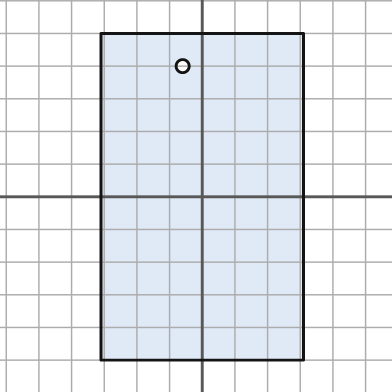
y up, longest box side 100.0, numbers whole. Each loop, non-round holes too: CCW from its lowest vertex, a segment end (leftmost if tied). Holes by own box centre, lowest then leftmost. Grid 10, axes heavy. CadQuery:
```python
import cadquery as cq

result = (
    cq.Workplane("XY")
    .moveTo(-31.0, -50.0)
    .lineTo(31.0, -50.0)
    .lineTo(31.0, 50.0)
    .lineTo(-31.0, 50.0)
    .close()
    .moveTo(-6.0, 40.0)
    .circle(2.0)
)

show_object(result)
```